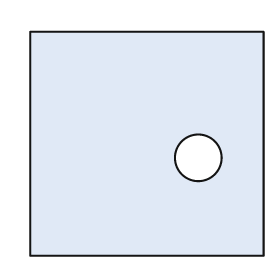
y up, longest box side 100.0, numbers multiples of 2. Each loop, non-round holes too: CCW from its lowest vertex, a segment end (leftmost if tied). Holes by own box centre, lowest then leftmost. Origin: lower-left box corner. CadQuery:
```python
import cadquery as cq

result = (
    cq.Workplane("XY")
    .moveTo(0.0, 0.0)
    .lineTo(100.0, 0.0)
    .lineTo(100.0, 96.0)
    .lineTo(0.0, 96.0)
    .close()
    .moveTo(72.0, 42.0)
    .circle(10.0)
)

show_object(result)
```